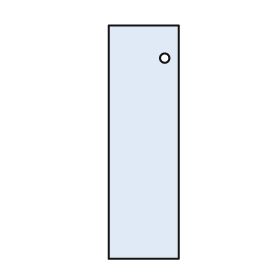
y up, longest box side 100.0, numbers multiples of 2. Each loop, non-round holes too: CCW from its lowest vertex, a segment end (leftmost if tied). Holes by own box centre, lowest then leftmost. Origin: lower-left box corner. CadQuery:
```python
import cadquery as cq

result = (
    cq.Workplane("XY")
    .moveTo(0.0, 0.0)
    .lineTo(30.0, 0.0)
    .lineTo(30.0, 100.0)
    .lineTo(0.0, 100.0)
    .close()
    .moveTo(24.0, 86.0)
    .circle(2.0)
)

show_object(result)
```